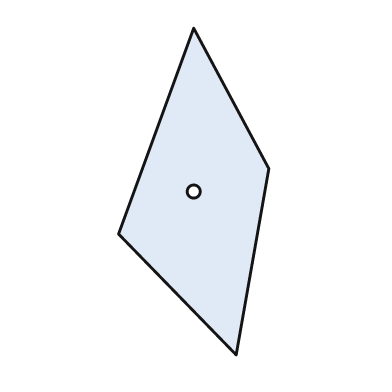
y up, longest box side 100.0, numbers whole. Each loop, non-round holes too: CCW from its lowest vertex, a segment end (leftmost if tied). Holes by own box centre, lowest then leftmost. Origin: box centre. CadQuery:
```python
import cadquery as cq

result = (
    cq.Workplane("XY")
    .moveTo(13.0, -50.0)
    .lineTo(23.0, 7.0)
    .lineTo(0.0, 50.0)
    .lineTo(-23.0, -13.0)
    .close()
    .moveTo(0.0, 0.0)
    .circle(2.0)
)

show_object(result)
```